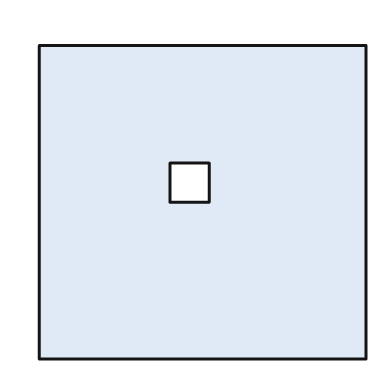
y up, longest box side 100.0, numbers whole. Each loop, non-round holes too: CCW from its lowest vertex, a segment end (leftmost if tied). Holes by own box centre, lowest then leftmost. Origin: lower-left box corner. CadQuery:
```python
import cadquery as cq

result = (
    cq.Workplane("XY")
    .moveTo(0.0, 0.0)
    .lineTo(100.0, 0.0)
    .lineTo(100.0, 96.0)
    .lineTo(0.0, 96.0)
    .close()
    .moveTo(40.0, 48.0)
    .lineTo(52.0, 48.0)
    .lineTo(52.0, 60.0)
    .lineTo(40.0, 60.0)
    .close()
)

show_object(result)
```